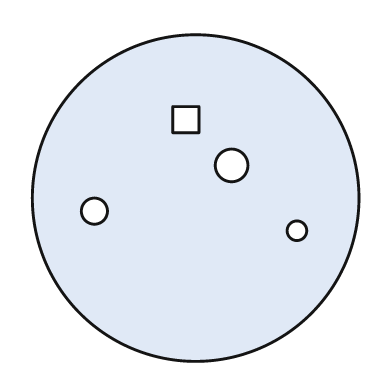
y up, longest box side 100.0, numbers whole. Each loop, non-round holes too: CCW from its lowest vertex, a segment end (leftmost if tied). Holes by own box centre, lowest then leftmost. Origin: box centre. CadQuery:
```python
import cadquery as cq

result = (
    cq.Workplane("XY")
    .moveTo(0.0, 0.0)
    .circle(50.0)
    .moveTo(31.0, -10.0)
    .circle(3.0)
    .moveTo(-31.0, -4.0)
    .circle(4.0)
    .moveTo(11.0, 10.0)
    .circle(5.0)
    .moveTo(-7.0, 20.0)
    .lineTo(1.0, 20.0)
    .lineTo(1.0, 28.0)
    .lineTo(-7.0, 28.0)
    .close()
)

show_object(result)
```